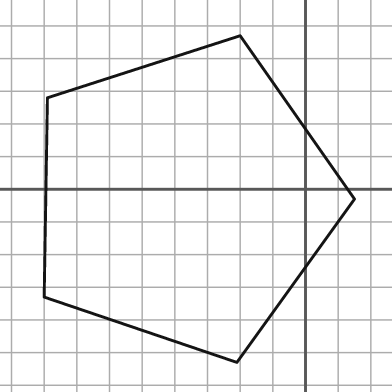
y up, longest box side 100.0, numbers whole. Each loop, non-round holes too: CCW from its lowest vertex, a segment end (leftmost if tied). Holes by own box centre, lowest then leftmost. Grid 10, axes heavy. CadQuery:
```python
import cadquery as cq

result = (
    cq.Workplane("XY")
    .moveTo(-21.0, -53.0)
    .lineTo(15.0, -3.0)
    .lineTo(-20.0, 47.0)
    .lineTo(-79.0, 28.0)
    .lineTo(-80.0, -33.0)
    .close()
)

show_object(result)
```